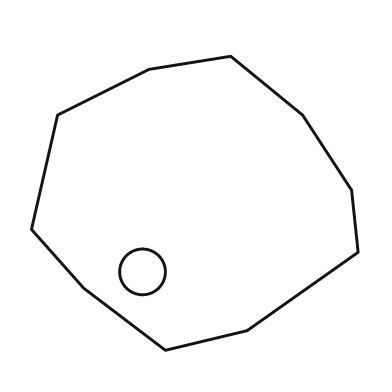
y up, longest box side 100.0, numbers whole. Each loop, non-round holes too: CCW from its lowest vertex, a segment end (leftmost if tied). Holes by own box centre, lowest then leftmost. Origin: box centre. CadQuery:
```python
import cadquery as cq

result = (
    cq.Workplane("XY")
    .moveTo(-9.0, -45.0)
    .lineTo(16.0, -39.0)
    .lineTo(50.0, -15.0)
    .lineTo(48.0, 4.0)
    .lineTo(33.0, 27.0)
    .lineTo(11.0, 45.0)
    .lineTo(-14.0, 41.0)
    .lineTo(-42.0, 27.0)
    .lineTo(-50.0, -8.0)
    .lineTo(-34.0, -26.0)
    .close()
    .moveTo(-16.0, -21.0)
    .circle(7.0)
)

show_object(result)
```